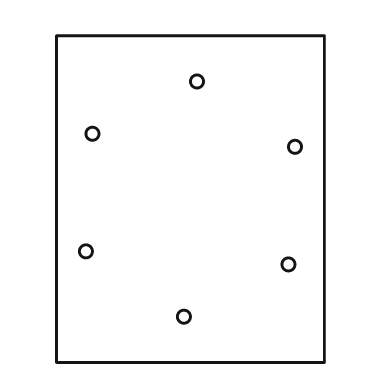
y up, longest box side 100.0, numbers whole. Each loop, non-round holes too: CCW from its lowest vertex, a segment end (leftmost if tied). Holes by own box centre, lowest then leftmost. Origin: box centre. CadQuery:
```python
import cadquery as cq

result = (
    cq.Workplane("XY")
    .moveTo(-41.0, -50.0)
    .lineTo(41.0, -50.0)
    .lineTo(41.0, 50.0)
    .lineTo(-41.0, 50.0)
    .close()
    .moveTo(-2.0, -36.0)
    .circle(2.0)
    .moveTo(30.0, -20.0)
    .circle(2.0)
    .moveTo(-32.0, -16.0)
    .circle(2.0)
    .moveTo(32.0, 16.0)
    .circle(2.0)
    .moveTo(-30.0, 20.0)
    .circle(2.0)
    .moveTo(2.0, 36.0)
    .circle(2.0)
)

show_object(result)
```